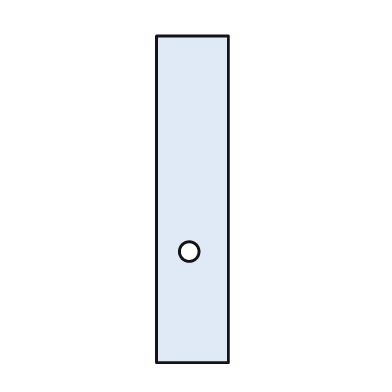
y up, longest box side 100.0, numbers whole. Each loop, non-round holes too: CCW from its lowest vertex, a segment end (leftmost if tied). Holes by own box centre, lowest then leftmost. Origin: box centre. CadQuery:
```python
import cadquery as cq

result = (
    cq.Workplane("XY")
    .moveTo(-11.0, -50.0)
    .lineTo(11.0, -50.0)
    .lineTo(11.0, 50.0)
    .lineTo(-11.0, 50.0)
    .close()
    .moveTo(-1.0, -16.0)
    .circle(3.0)
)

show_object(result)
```